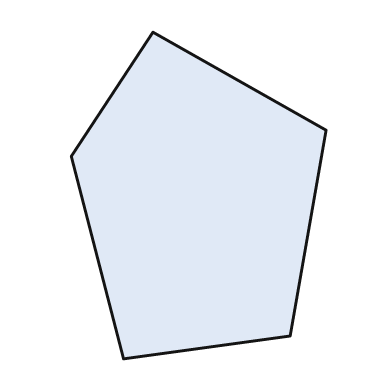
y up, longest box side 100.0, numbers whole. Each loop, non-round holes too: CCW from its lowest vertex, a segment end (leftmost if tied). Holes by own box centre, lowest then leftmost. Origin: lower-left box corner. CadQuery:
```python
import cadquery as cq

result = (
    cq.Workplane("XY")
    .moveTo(16.0, 0.0)
    .lineTo(67.0, 7.0)
    .lineTo(78.0, 70.0)
    .lineTo(25.0, 100.0)
    .lineTo(0.0, 62.0)
    .close()
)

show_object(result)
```